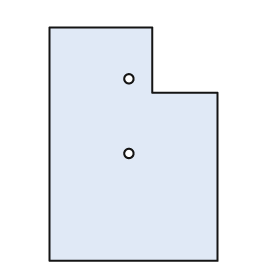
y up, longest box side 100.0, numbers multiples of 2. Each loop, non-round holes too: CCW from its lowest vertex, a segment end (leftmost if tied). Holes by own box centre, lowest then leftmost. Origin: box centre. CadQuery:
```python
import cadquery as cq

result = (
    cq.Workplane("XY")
    .moveTo(-36.0, -50.0)
    .lineTo(36.0, -50.0)
    .lineTo(36.0, 22.0)
    .lineTo(8.0, 22.0)
    .lineTo(8.0, 50.0)
    .lineTo(-36.0, 50.0)
    .close()
    .moveTo(-2.0, -4.0)
    .circle(2.0)
    .moveTo(-2.0, 28.0)
    .circle(2.0)
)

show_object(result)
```